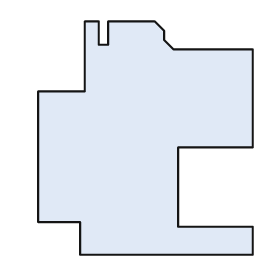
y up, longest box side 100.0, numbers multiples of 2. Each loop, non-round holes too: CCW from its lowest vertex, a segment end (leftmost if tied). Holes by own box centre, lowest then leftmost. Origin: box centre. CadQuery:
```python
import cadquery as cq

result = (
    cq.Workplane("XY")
    .moveTo(-28.0, -50.0)
    .lineTo(46.0, -50.0)
    .lineTo(46.0, -38.0)
    .lineTo(14.0, -38.0)
    .lineTo(14.0, -4.0)
    .lineTo(46.0, -4.0)
    .lineTo(46.0, 38.0)
    .lineTo(12.0, 38.0)
    .lineTo(8.0, 42.0)
    .lineTo(8.0, 46.0)
    .lineTo(4.0, 50.0)
    .lineTo(-16.0, 50.0)
    .lineTo(-16.0, 40.0)
    .lineTo(-20.0, 40.0)
    .lineTo(-20.0, 50.0)
    .lineTo(-26.0, 50.0)
    .lineTo(-26.0, 20.0)
    .lineTo(-46.0, 20.0)
    .lineTo(-46.0, -36.0)
    .lineTo(-28.0, -36.0)
    .close()
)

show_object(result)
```